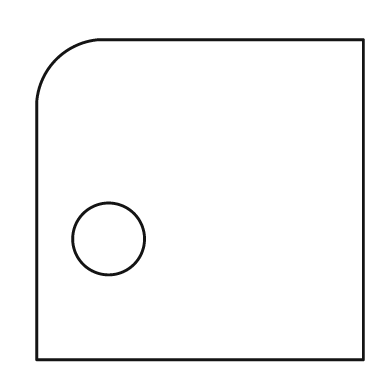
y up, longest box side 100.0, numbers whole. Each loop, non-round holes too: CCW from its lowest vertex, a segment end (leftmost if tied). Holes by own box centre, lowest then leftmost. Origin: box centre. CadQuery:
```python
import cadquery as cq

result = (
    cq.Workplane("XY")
    .moveTo(-50.0, -49.0)
    .lineTo(50.0, -49.0)
    .lineTo(50.0, 49.0)
    .lineTo(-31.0, 49.0)
    .threePointArc((-44.0, 43.0), (-50.0, 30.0))
    .close()
    .moveTo(-28.0, -12.0)
    .circle(11.0)
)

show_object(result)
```